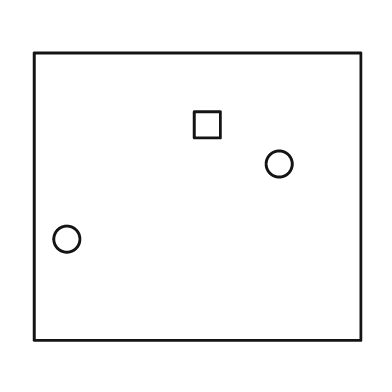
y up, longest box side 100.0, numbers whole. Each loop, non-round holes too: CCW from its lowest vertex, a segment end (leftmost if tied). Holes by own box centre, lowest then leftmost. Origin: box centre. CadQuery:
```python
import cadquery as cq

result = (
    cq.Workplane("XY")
    .moveTo(-50.0, -44.0)
    .lineTo(50.0, -44.0)
    .lineTo(50.0, 44.0)
    .lineTo(-50.0, 44.0)
    .close()
    .moveTo(-40.0, -13.0)
    .circle(4.0)
    .moveTo(25.0, 10.0)
    .circle(4.0)
    .moveTo(-1.0, 18.0)
    .lineTo(7.0, 18.0)
    .lineTo(7.0, 26.0)
    .lineTo(-1.0, 26.0)
    .close()
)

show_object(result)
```